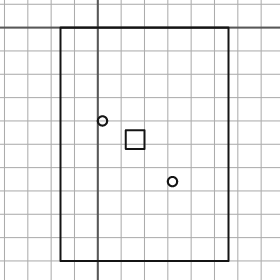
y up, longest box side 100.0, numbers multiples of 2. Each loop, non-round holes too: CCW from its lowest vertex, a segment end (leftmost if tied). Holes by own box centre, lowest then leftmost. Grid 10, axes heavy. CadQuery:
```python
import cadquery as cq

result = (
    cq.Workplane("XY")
    .moveTo(-16.0, -100.0)
    .lineTo(56.0, -100.0)
    .lineTo(56.0, 0.0)
    .lineTo(-16.0, 0.0)
    .close()
    .moveTo(32.0, -66.0)
    .circle(2.0)
    .moveTo(12.0, -52.0)
    .lineTo(20.0, -52.0)
    .lineTo(20.0, -44.0)
    .lineTo(12.0, -44.0)
    .close()
    .moveTo(2.0, -40.0)
    .circle(2.0)
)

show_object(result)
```